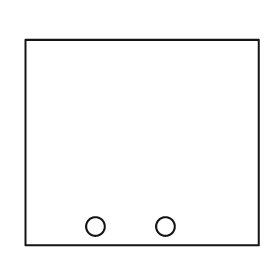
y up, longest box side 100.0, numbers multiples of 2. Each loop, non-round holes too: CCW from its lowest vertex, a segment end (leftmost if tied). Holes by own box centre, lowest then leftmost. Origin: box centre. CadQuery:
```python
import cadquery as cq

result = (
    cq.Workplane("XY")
    .moveTo(-50.0, -44.0)
    .lineTo(50.0, -44.0)
    .lineTo(50.0, 44.0)
    .lineTo(-50.0, 44.0)
    .close()
    .moveTo(-20.0, -36.0)
    .circle(4.0)
    .moveTo(10.0, -36.0)
    .circle(4.0)
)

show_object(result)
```